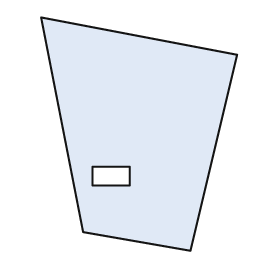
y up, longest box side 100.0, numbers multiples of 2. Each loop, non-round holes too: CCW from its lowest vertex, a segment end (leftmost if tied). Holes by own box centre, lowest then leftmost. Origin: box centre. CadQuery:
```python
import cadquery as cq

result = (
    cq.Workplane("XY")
    .moveTo(22.0, -50.0)
    .lineTo(42.0, 34.0)
    .lineTo(-42.0, 50.0)
    .lineTo(-24.0, -42.0)
    .close()
    .moveTo(-20.0, -22.0)
    .lineTo(-4.0, -22.0)
    .lineTo(-4.0, -14.0)
    .lineTo(-20.0, -14.0)
    .close()
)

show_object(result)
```